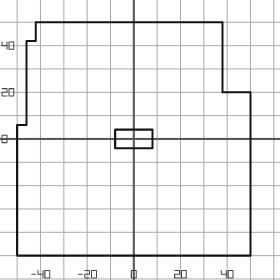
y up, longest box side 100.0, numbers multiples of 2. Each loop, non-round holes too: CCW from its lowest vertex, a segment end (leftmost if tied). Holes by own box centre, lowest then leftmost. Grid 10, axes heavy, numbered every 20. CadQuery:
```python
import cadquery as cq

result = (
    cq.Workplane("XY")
    .moveTo(-50.0, -50.0)
    .lineTo(50.0, -50.0)
    .lineTo(50.0, 20.0)
    .lineTo(38.0, 20.0)
    .lineTo(38.0, 50.0)
    .lineTo(-42.0, 50.0)
    .lineTo(-42.0, 42.0)
    .lineTo(-46.0, 42.0)
    .lineTo(-46.0, 6.0)
    .lineTo(-50.0, 6.0)
    .close()
    .moveTo(-8.0, -4.0)
    .lineTo(8.0, -4.0)
    .lineTo(8.0, 4.0)
    .lineTo(-8.0, 4.0)
    .close()
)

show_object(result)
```